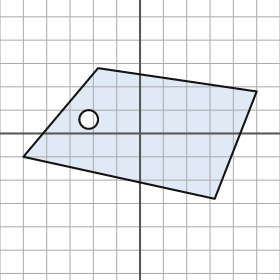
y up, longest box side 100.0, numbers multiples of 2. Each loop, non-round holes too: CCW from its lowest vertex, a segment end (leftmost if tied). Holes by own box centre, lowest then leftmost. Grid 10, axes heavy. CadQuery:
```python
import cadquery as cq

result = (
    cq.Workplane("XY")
    .moveTo(32.0, -28.0)
    .lineTo(50.0, 18.0)
    .lineTo(-18.0, 28.0)
    .lineTo(-50.0, -10.0)
    .close()
    .moveTo(-22.0, 6.0)
    .circle(4.0)
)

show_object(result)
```